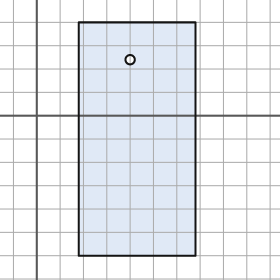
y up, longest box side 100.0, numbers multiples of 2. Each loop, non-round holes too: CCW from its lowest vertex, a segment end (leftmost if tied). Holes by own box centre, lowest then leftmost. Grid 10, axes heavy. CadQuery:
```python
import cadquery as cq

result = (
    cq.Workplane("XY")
    .moveTo(18.0, -60.0)
    .lineTo(68.0, -60.0)
    .lineTo(68.0, 40.0)
    .lineTo(18.0, 40.0)
    .close()
    .moveTo(40.0, 24.0)
    .circle(2.0)
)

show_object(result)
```